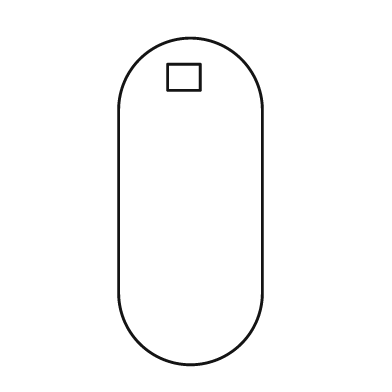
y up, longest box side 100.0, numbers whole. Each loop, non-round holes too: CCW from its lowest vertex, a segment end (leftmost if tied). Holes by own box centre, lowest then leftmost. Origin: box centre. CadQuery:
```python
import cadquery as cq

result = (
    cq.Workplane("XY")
    .moveTo(-22.0, -28.0)
    .threePointArc((0.0, -50.0), (22.0, -28.0))
    .lineTo(22.0, 28.0)
    .threePointArc((0.0, 50.0), (-22.0, 28.0))
    .close()
    .moveTo(-7.0, 34.0)
    .lineTo(3.0, 34.0)
    .lineTo(3.0, 42.0)
    .lineTo(-7.0, 42.0)
    .close()
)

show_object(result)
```